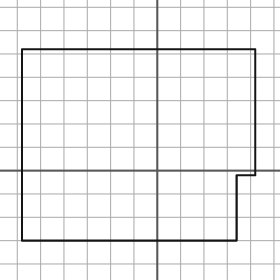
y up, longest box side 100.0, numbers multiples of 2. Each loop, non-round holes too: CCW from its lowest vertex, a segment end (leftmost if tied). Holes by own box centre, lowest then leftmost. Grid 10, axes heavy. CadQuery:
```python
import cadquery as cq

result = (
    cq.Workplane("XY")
    .moveTo(-58.0, -30.0)
    .lineTo(34.0, -30.0)
    .lineTo(34.0, -2.0)
    .lineTo(42.0, -2.0)
    .lineTo(42.0, 52.0)
    .lineTo(-58.0, 52.0)
    .close()
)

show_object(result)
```